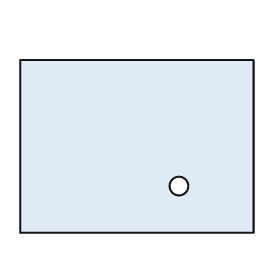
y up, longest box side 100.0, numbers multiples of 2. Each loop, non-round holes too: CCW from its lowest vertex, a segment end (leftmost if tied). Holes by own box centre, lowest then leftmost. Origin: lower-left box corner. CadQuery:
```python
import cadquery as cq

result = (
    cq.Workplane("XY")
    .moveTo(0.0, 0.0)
    .lineTo(100.0, 0.0)
    .lineTo(100.0, 74.0)
    .lineTo(0.0, 74.0)
    .close()
    .moveTo(68.0, 20.0)
    .circle(4.0)
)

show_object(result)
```